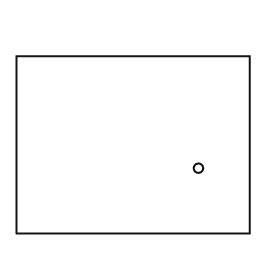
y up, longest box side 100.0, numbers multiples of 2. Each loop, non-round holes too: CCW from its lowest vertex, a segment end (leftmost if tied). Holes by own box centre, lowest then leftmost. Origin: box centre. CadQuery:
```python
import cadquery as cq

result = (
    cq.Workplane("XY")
    .moveTo(-50.0, -38.0)
    .lineTo(50.0, -38.0)
    .lineTo(50.0, 38.0)
    .lineTo(-50.0, 38.0)
    .close()
    .moveTo(28.0, -10.0)
    .circle(2.0)
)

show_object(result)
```